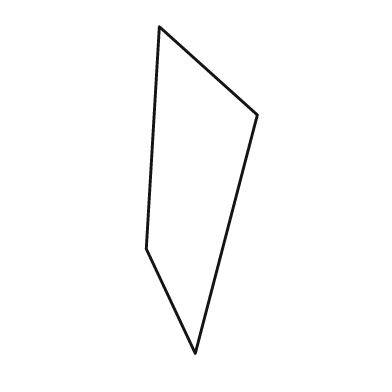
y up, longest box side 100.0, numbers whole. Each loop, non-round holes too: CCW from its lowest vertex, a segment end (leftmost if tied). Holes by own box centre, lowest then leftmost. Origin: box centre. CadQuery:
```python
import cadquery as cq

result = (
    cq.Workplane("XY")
    .moveTo(-2.0, -50.0)
    .lineTo(17.0, 23.0)
    .lineTo(-13.0, 50.0)
    .lineTo(-17.0, -18.0)
    .close()
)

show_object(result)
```